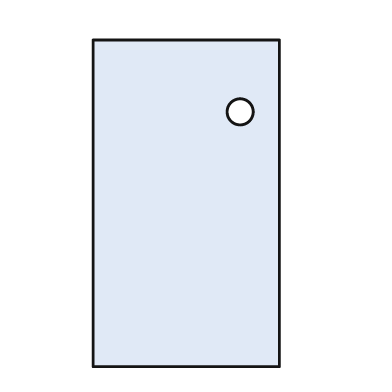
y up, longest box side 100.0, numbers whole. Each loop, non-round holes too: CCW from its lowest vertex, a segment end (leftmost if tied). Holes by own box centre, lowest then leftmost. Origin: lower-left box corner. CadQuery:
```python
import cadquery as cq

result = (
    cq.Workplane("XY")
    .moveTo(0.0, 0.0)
    .lineTo(57.0, 0.0)
    .lineTo(57.0, 100.0)
    .lineTo(0.0, 100.0)
    .close()
    .moveTo(45.0, 78.0)
    .circle(4.0)
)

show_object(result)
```